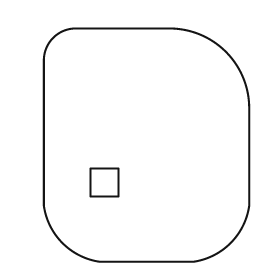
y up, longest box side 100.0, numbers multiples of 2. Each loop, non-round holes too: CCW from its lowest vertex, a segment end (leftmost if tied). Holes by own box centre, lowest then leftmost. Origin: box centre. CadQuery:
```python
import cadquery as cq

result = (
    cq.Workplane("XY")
    .moveTo(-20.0, -50.0)
    .lineTo(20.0, -50.0)
    .threePointArc((36.0, -42.0), (44.0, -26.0))
    .lineTo(44.0, 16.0)
    .threePointArc((34.0, 40.0), (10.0, 50.0))
    .lineTo(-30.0, 50.0)
    .threePointArc((-40.0, 46.0), (-44.0, 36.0))
    .lineTo(-44.0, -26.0)
    .threePointArc((-36.0, -42.0), (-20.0, -50.0))
    .close()
    .moveTo(-24.0, -22.0)
    .lineTo(-12.0, -22.0)
    .lineTo(-12.0, -10.0)
    .lineTo(-24.0, -10.0)
    .close()
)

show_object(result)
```